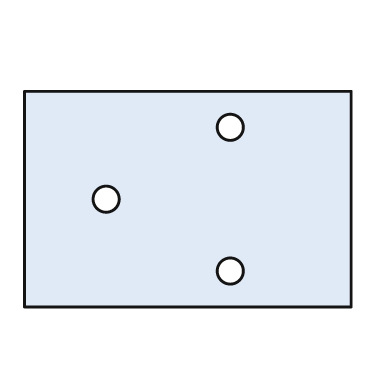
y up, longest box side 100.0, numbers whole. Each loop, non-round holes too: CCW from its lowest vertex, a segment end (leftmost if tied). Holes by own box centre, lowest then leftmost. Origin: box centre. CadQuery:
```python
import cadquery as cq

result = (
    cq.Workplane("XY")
    .moveTo(-50.0, -33.0)
    .lineTo(50.0, -33.0)
    .lineTo(50.0, 33.0)
    .lineTo(-50.0, 33.0)
    .close()
    .moveTo(13.0, -22.0)
    .circle(4.0)
    .moveTo(-25.0, 0.0)
    .circle(4.0)
    .moveTo(13.0, 22.0)
    .circle(4.0)
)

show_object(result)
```